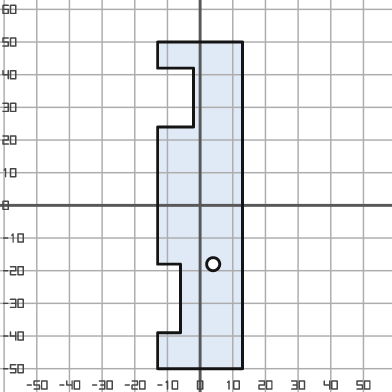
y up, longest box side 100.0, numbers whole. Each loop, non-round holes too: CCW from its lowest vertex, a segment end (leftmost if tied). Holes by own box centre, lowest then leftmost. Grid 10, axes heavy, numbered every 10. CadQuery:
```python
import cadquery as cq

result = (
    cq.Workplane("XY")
    .moveTo(-13.0, -50.0)
    .lineTo(13.0, -50.0)
    .lineTo(13.0, 50.0)
    .lineTo(-13.0, 50.0)
    .lineTo(-13.0, 42.0)
    .lineTo(-2.0, 42.0)
    .lineTo(-2.0, 24.0)
    .lineTo(-13.0, 24.0)
    .lineTo(-13.0, -18.0)
    .lineTo(-6.0, -18.0)
    .lineTo(-6.0, -39.0)
    .lineTo(-13.0, -39.0)
    .close()
    .moveTo(4.0, -18.0)
    .circle(2.0)
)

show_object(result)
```